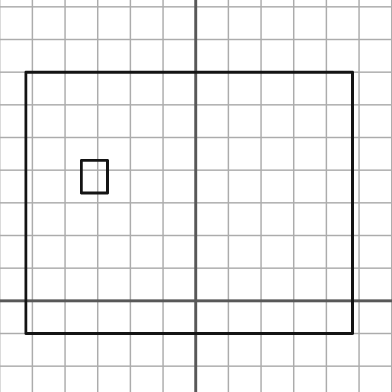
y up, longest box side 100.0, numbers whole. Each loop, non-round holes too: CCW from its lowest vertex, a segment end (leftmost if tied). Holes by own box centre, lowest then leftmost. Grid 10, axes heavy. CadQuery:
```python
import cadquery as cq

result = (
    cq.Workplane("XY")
    .moveTo(-52.0, -10.0)
    .lineTo(48.0, -10.0)
    .lineTo(48.0, 70.0)
    .lineTo(-52.0, 70.0)
    .close()
    .moveTo(-35.0, 33.0)
    .lineTo(-27.0, 33.0)
    .lineTo(-27.0, 43.0)
    .lineTo(-35.0, 43.0)
    .close()
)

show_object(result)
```